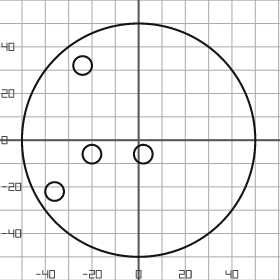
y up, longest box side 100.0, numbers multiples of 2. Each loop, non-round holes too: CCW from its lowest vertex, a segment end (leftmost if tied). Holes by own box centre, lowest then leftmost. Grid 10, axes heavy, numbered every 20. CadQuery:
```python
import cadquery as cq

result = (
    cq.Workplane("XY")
    .moveTo(0.0, 0.0)
    .circle(50.0)
    .moveTo(-36.0, -22.0)
    .circle(4.0)
    .moveTo(-20.0, -6.0)
    .circle(4.0)
    .moveTo(2.0, -6.0)
    .circle(4.0)
    .moveTo(-24.0, 32.0)
    .circle(4.0)
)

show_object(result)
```